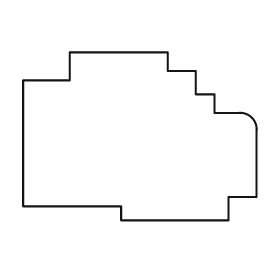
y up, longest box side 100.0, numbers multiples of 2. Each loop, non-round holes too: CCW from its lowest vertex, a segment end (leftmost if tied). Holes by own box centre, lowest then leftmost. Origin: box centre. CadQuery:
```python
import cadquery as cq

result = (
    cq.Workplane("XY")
    .moveTo(-8.0, -36.0)
    .lineTo(38.0, -36.0)
    .lineTo(38.0, -26.0)
    .lineTo(50.0, -26.0)
    .lineTo(50.0, 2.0)
    .threePointArc((48.0, 8.0), (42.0, 10.0))
    .lineTo(32.0, 10.0)
    .lineTo(32.0, 18.0)
    .lineTo(24.0, 18.0)
    .lineTo(24.0, 28.0)
    .lineTo(12.0, 28.0)
    .lineTo(12.0, 36.0)
    .lineTo(-30.0, 36.0)
    .lineTo(-30.0, 24.0)
    .lineTo(-50.0, 24.0)
    .lineTo(-50.0, -30.0)
    .lineTo(-8.0, -30.0)
    .close()
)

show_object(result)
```